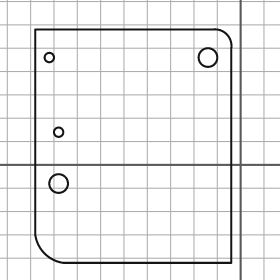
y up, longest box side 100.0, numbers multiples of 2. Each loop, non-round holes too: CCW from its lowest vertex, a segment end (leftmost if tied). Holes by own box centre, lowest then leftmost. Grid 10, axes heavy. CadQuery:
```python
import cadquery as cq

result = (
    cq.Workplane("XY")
    .moveTo(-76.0, -42.0)
    .lineTo(-4.0, -42.0)
    .lineTo(-4.0, 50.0)
    .threePointArc((-6.0, 56.0), (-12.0, 58.0))
    .lineTo(-88.0, 58.0)
    .lineTo(-88.0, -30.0)
    .threePointArc((-84.0, -38.0), (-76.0, -42.0))
    .close()
    .moveTo(-78.0, -8.0)
    .circle(4.0)
    .moveTo(-78.0, 14.0)
    .circle(2.0)
    .moveTo(-82.0, 46.0)
    .circle(2.0)
    .moveTo(-14.0, 46.0)
    .circle(4.0)
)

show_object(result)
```